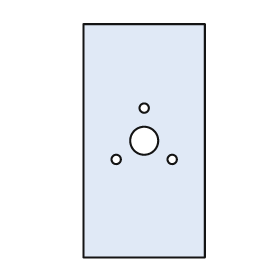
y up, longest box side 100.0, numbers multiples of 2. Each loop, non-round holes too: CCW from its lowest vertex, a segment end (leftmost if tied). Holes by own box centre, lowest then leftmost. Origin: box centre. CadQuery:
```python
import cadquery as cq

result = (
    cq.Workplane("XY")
    .moveTo(-26.0, -50.0)
    .lineTo(26.0, -50.0)
    .lineTo(26.0, 50.0)
    .lineTo(-26.0, 50.0)
    .close()
    .moveTo(-12.0, -8.0)
    .circle(2.0)
    .moveTo(12.0, -8.0)
    .circle(2.0)
    .moveTo(0.0, 0.0)
    .circle(6.0)
    .moveTo(0.0, 14.0)
    .circle(2.0)
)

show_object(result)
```